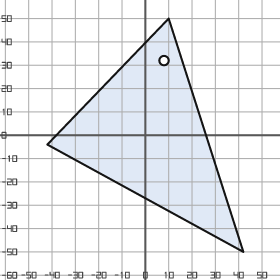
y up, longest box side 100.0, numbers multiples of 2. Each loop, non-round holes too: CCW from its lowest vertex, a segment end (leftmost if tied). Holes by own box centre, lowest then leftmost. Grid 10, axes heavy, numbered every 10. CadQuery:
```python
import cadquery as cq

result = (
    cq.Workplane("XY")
    .moveTo(42.0, -50.0)
    .lineTo(10.0, 50.0)
    .lineTo(-42.0, -4.0)
    .close()
    .moveTo(8.0, 32.0)
    .circle(2.0)
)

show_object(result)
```